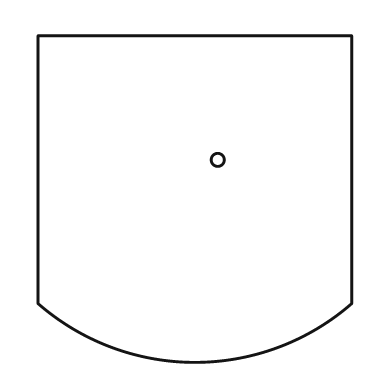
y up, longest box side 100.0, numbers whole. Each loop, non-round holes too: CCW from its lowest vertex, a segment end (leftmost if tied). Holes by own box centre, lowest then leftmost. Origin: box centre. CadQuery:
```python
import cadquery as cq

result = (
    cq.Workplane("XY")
    .moveTo(-48.0, -32.0)
    .threePointArc((0.0, -50.0), (48.0, -32.0))
    .lineTo(48.0, 50.0)
    .lineTo(-48.0, 50.0)
    .close()
    .moveTo(7.0, 12.0)
    .circle(2.0)
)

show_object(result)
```